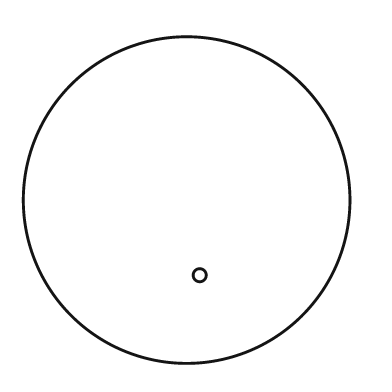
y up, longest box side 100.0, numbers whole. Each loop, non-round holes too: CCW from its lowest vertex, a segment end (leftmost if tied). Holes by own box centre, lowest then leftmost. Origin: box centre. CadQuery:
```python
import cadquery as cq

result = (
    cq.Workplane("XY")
    .moveTo(0.0, 0.0)
    .circle(50.0)
    .moveTo(4.0, -23.0)
    .circle(2.0)
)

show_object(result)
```